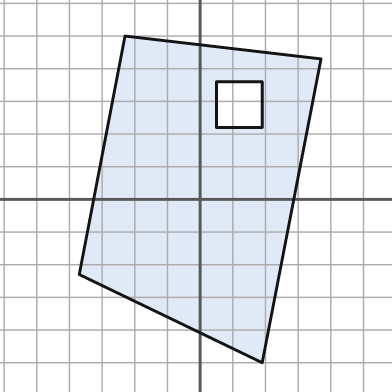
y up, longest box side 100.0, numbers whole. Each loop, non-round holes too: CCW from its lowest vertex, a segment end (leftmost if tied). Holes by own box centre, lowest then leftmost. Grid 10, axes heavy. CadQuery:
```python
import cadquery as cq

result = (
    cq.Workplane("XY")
    .moveTo(19.0, -50.0)
    .lineTo(37.0, 43.0)
    .lineTo(-23.0, 50.0)
    .lineTo(-37.0, -23.0)
    .close()
    .moveTo(5.0, 22.0)
    .lineTo(19.0, 22.0)
    .lineTo(19.0, 36.0)
    .lineTo(5.0, 36.0)
    .close()
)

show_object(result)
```